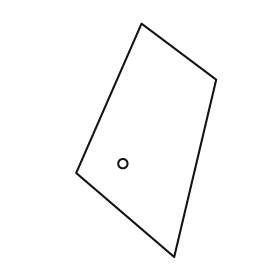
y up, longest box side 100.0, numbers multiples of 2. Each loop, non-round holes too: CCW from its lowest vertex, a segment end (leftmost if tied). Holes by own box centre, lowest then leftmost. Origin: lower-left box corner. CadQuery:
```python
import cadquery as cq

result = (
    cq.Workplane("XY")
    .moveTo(42.0, 0.0)
    .lineTo(60.0, 76.0)
    .lineTo(28.0, 100.0)
    .lineTo(0.0, 36.0)
    .close()
    .moveTo(20.0, 40.0)
    .circle(2.0)
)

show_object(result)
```